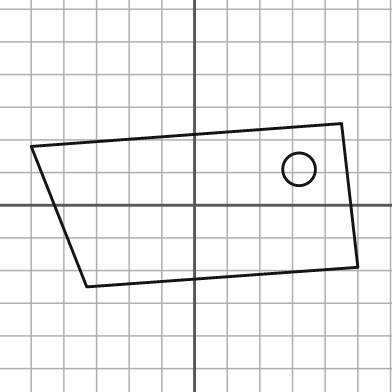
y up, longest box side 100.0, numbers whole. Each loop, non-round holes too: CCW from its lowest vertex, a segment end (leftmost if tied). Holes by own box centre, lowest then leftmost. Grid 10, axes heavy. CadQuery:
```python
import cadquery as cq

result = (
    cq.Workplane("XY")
    .moveTo(-33.0, -25.0)
    .lineTo(50.0, -19.0)
    .lineTo(45.0, 25.0)
    .lineTo(-50.0, 18.0)
    .close()
    .moveTo(32.0, 11.0)
    .circle(5.0)
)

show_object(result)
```